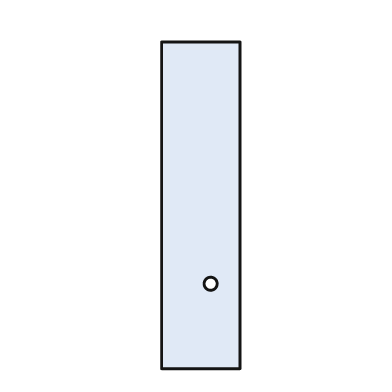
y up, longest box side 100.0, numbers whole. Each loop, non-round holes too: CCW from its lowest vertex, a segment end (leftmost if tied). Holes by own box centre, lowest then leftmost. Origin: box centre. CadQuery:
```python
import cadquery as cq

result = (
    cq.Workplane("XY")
    .moveTo(-12.0, -50.0)
    .lineTo(12.0, -50.0)
    .lineTo(12.0, 50.0)
    .lineTo(-12.0, 50.0)
    .close()
    .moveTo(3.0, -24.0)
    .circle(2.0)
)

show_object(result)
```